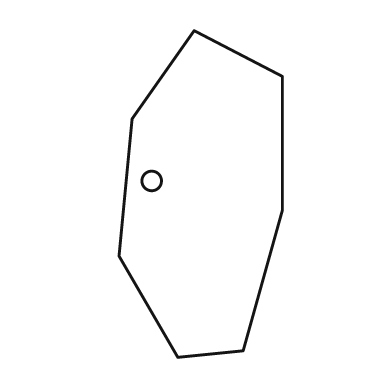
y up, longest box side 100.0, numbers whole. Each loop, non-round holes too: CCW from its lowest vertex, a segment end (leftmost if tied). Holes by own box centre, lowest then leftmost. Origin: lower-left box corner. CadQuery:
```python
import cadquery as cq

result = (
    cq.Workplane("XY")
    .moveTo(18.0, 0.0)
    .lineTo(38.0, 2.0)
    .lineTo(50.0, 45.0)
    .lineTo(50.0, 86.0)
    .lineTo(23.0, 100.0)
    .lineTo(4.0, 73.0)
    .lineTo(0.0, 31.0)
    .close()
    .moveTo(10.0, 54.0)
    .circle(3.0)
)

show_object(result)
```